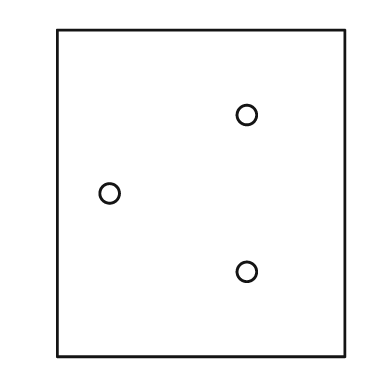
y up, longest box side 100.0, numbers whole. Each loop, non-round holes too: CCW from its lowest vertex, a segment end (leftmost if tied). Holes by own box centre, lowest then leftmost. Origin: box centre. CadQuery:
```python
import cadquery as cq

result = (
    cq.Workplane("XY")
    .moveTo(-44.0, -50.0)
    .lineTo(44.0, -50.0)
    .lineTo(44.0, 50.0)
    .lineTo(-44.0, 50.0)
    .close()
    .moveTo(14.0, -24.0)
    .circle(3.0)
    .moveTo(-28.0, 0.0)
    .circle(3.0)
    .moveTo(14.0, 24.0)
    .circle(3.0)
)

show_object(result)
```